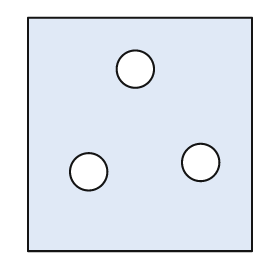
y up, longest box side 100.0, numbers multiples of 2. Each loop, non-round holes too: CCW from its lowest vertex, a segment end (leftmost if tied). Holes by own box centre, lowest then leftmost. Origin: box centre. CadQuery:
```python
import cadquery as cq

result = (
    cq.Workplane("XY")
    .moveTo(-48.0, -50.0)
    .lineTo(48.0, -50.0)
    .lineTo(48.0, 50.0)
    .lineTo(-48.0, 50.0)
    .close()
    .moveTo(-22.0, -16.0)
    .circle(8.0)
    .moveTo(26.0, -12.0)
    .circle(8.0)
    .moveTo(-2.0, 28.0)
    .circle(8.0)
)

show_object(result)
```